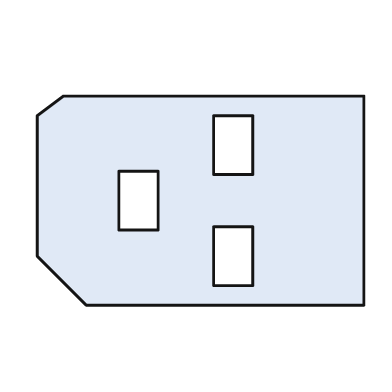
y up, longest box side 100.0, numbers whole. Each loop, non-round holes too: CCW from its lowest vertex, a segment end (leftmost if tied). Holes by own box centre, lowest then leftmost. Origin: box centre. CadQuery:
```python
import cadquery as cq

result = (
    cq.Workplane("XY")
    .moveTo(-35.0, -32.0)
    .lineTo(50.0, -32.0)
    .lineTo(50.0, 32.0)
    .lineTo(-42.0, 32.0)
    .lineTo(-50.0, 26.0)
    .lineTo(-50.0, -17.0)
    .close()
    .moveTo(4.0, -26.0)
    .lineTo(16.0, -26.0)
    .lineTo(16.0, -8.0)
    .lineTo(4.0, -8.0)
    .close()
    .moveTo(-25.0, -9.0)
    .lineTo(-13.0, -9.0)
    .lineTo(-13.0, 9.0)
    .lineTo(-25.0, 9.0)
    .close()
    .moveTo(4.0, 8.0)
    .lineTo(16.0, 8.0)
    .lineTo(16.0, 26.0)
    .lineTo(4.0, 26.0)
    .close()
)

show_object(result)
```